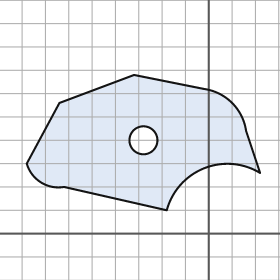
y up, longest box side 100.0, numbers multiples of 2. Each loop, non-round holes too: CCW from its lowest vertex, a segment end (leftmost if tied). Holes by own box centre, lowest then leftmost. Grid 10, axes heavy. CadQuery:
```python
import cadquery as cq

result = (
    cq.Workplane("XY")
    .moveTo(-18.0, 10.0)
    .threePointArc((-2.0, 28.0), (22.0, 26.0))
    .lineTo(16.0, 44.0)
    .threePointArc((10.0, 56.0), (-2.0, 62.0))
    .lineTo(-32.0, 68.0)
    .lineTo(-64.0, 56.0)
    .lineTo(-78.0, 30.0)
    .threePointArc((-72.0, 22.0), (-62.0, 20.0))
    .close()
    .moveTo(-28.0, 40.0)
    .circle(6.0)
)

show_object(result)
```